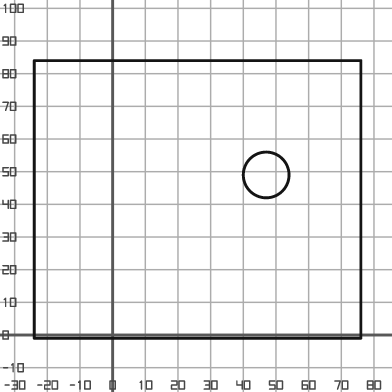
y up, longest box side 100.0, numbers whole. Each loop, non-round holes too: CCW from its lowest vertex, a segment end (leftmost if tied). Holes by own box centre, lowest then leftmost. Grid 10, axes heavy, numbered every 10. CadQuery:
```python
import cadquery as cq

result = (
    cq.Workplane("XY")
    .moveTo(-24.0, -1.0)
    .lineTo(76.0, -1.0)
    .lineTo(76.0, 84.0)
    .lineTo(-24.0, 84.0)
    .close()
    .moveTo(47.0, 49.0)
    .circle(7.0)
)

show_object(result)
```